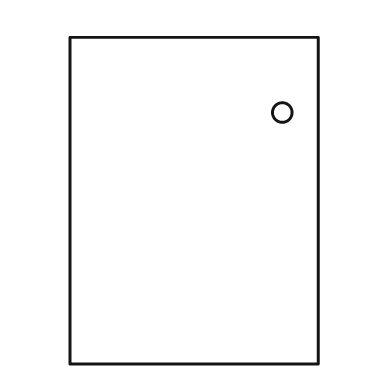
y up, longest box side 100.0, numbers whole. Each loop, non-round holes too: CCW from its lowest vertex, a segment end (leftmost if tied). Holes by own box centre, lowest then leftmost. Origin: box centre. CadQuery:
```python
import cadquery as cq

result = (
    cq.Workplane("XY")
    .moveTo(-38.0, -50.0)
    .lineTo(38.0, -50.0)
    .lineTo(38.0, 50.0)
    .lineTo(-38.0, 50.0)
    .close()
    .moveTo(27.0, 27.0)
    .circle(3.0)
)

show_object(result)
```